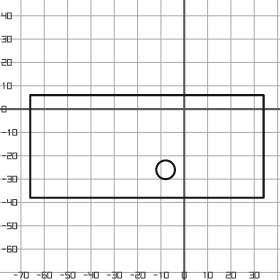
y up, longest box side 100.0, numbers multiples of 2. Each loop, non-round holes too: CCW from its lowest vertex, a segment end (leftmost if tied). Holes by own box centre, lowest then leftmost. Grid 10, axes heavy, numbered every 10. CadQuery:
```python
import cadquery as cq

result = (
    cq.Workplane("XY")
    .moveTo(-66.0, -38.0)
    .lineTo(34.0, -38.0)
    .lineTo(34.0, 6.0)
    .lineTo(-66.0, 6.0)
    .close()
    .moveTo(-8.0, -26.0)
    .circle(4.0)
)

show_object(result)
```